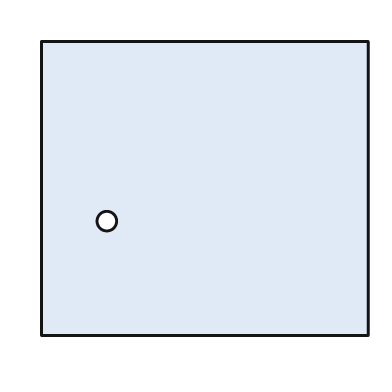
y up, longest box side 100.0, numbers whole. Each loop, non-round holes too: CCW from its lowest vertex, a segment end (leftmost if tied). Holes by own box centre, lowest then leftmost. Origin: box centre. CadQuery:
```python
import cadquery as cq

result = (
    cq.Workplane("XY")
    .moveTo(-50.0, -45.0)
    .lineTo(50.0, -45.0)
    .lineTo(50.0, 45.0)
    .lineTo(-50.0, 45.0)
    .close()
    .moveTo(-30.0, -10.0)
    .circle(3.0)
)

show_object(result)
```